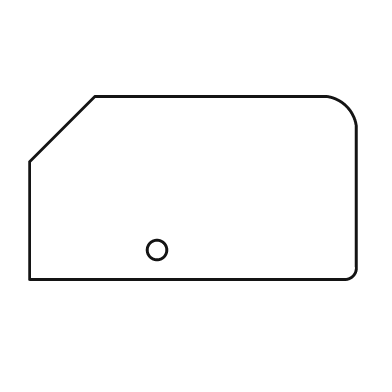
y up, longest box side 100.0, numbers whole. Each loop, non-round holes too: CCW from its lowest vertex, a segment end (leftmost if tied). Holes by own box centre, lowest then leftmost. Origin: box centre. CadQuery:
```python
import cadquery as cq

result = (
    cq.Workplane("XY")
    .moveTo(-50.0, -28.0)
    .lineTo(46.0, -28.0)
    .threePointArc((49.0, -27.0), (50.0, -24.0))
    .lineTo(50.0, 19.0)
    .threePointArc((47.0, 25.0), (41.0, 28.0))
    .lineTo(-30.0, 28.0)
    .lineTo(-50.0, 8.0)
    .close()
    .moveTo(-11.0, -19.0)
    .circle(3.0)
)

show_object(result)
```